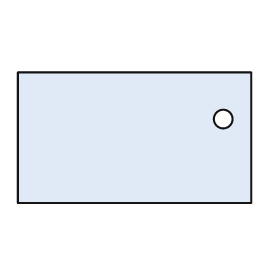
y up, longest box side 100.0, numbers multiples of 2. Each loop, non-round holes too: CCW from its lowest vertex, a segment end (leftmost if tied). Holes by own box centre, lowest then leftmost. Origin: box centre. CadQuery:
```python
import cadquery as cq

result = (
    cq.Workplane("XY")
    .moveTo(-50.0, -28.0)
    .lineTo(50.0, -28.0)
    .lineTo(50.0, 28.0)
    .lineTo(-50.0, 28.0)
    .close()
    .moveTo(38.0, 8.0)
    .circle(4.0)
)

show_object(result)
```